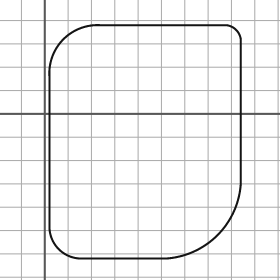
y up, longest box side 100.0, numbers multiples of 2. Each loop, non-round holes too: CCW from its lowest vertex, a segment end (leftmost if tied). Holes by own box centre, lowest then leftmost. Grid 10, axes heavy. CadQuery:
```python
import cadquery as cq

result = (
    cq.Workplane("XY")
    .moveTo(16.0, -62.0)
    .lineTo(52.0, -62.0)
    .threePointArc((74.0, -52.0), (84.0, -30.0))
    .lineTo(84.0, 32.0)
    .threePointArc((82.0, 36.0), (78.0, 38.0))
    .lineTo(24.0, 38.0)
    .threePointArc((8.0, 32.0), (2.0, 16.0))
    .lineTo(2.0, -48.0)
    .threePointArc((6.0, -58.0), (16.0, -62.0))
    .close()
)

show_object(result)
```